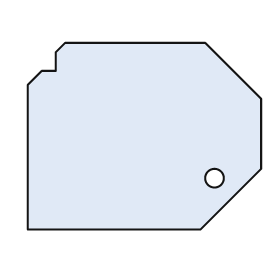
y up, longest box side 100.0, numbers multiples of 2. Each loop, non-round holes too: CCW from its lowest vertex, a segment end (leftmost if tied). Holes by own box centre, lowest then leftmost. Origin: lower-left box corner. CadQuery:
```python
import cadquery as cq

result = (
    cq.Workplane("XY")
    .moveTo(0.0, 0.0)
    .lineTo(74.0, 0.0)
    .lineTo(100.0, 26.0)
    .lineTo(100.0, 56.0)
    .lineTo(76.0, 80.0)
    .lineTo(16.0, 80.0)
    .lineTo(12.0, 76.0)
    .lineTo(12.0, 68.0)
    .lineTo(6.0, 68.0)
    .lineTo(0.0, 62.0)
    .close()
    .moveTo(80.0, 22.0)
    .circle(4.0)
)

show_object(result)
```